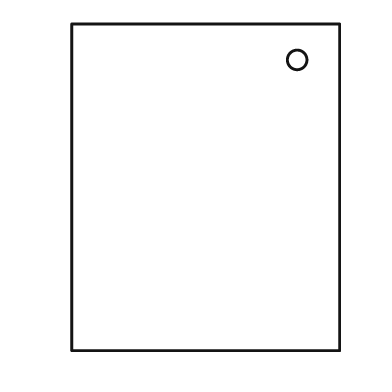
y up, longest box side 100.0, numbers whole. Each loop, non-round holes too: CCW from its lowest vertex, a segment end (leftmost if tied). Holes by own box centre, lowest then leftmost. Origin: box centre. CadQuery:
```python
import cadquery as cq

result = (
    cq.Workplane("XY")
    .moveTo(-41.0, -50.0)
    .lineTo(41.0, -50.0)
    .lineTo(41.0, 50.0)
    .lineTo(-41.0, 50.0)
    .close()
    .moveTo(28.0, 39.0)
    .circle(3.0)
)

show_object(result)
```